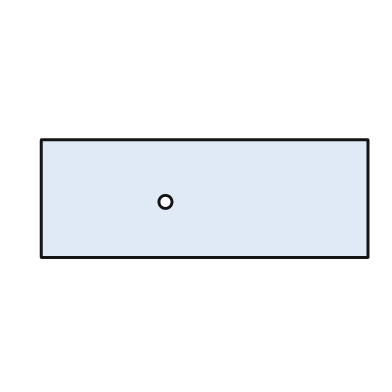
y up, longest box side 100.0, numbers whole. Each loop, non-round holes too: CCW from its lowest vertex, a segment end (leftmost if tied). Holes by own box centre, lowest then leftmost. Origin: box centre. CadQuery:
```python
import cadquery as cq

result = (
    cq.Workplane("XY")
    .moveTo(-50.0, -18.0)
    .lineTo(50.0, -18.0)
    .lineTo(50.0, 18.0)
    .lineTo(-50.0, 18.0)
    .close()
    .moveTo(-12.0, -1.0)
    .circle(2.0)
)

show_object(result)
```